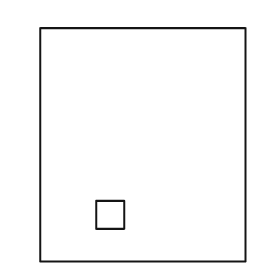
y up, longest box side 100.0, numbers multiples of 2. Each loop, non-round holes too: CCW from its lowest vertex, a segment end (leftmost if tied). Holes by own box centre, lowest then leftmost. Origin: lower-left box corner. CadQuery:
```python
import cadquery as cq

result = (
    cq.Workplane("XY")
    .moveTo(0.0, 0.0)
    .lineTo(88.0, 0.0)
    .lineTo(88.0, 100.0)
    .lineTo(0.0, 100.0)
    .close()
    .moveTo(24.0, 14.0)
    .lineTo(36.0, 14.0)
    .lineTo(36.0, 26.0)
    .lineTo(24.0, 26.0)
    .close()
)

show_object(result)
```